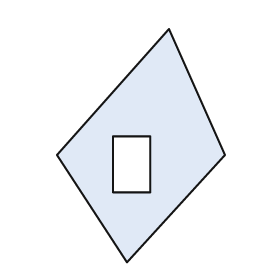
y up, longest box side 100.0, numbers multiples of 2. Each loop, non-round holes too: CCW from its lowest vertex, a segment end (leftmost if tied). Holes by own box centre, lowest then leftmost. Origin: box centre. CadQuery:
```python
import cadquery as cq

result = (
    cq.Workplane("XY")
    .moveTo(-6.0, -50.0)
    .lineTo(36.0, -4.0)
    .lineTo(12.0, 50.0)
    .lineTo(-36.0, -4.0)
    .close()
    .moveTo(-12.0, -20.0)
    .lineTo(4.0, -20.0)
    .lineTo(4.0, 4.0)
    .lineTo(-12.0, 4.0)
    .close()
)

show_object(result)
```